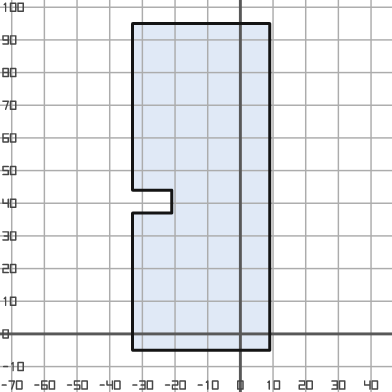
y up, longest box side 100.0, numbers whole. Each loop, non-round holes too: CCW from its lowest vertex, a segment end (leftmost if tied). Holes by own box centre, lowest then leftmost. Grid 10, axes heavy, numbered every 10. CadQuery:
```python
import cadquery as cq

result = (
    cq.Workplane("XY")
    .moveTo(-33.0, -5.0)
    .lineTo(9.0, -5.0)
    .lineTo(9.0, 95.0)
    .lineTo(-33.0, 95.0)
    .lineTo(-33.0, 44.0)
    .lineTo(-21.0, 44.0)
    .lineTo(-21.0, 37.0)
    .lineTo(-33.0, 37.0)
    .close()
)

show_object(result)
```